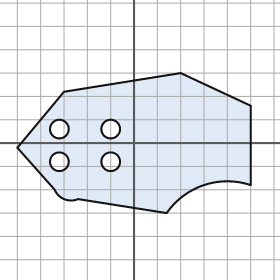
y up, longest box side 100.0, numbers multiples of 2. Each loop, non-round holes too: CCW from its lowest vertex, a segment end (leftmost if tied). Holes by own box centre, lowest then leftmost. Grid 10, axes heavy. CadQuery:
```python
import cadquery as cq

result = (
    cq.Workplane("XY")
    .moveTo(14.0, -30.0)
    .threePointArc((30.0, -18.0), (50.0, -18.0))
    .lineTo(50.0, 16.0)
    .lineTo(20.0, 30.0)
    .lineTo(-30.0, 22.0)
    .lineTo(-50.0, -2.0)
    .lineTo(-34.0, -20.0)
    .threePointArc((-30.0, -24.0), (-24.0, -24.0))
    .close()
    .moveTo(-32.0, -8.0)
    .circle(4.0)
    .moveTo(-10.0, -8.0)
    .circle(4.0)
    .moveTo(-32.0, 6.0)
    .circle(4.0)
    .moveTo(-10.0, 6.0)
    .circle(4.0)
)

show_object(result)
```